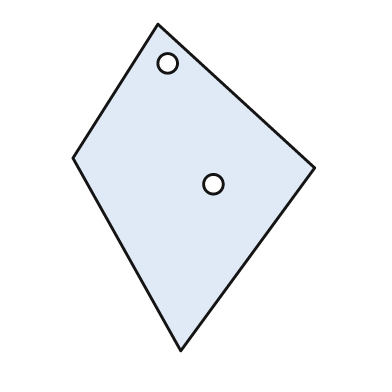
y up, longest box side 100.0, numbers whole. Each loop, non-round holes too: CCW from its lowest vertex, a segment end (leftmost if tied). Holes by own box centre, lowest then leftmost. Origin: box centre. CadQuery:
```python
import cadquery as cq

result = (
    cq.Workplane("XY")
    .moveTo(-4.0, -50.0)
    .lineTo(37.0, 6.0)
    .lineTo(-11.0, 50.0)
    .lineTo(-37.0, 9.0)
    .close()
    .moveTo(6.0, 1.0)
    .circle(3.0)
    .moveTo(-8.0, 38.0)
    .circle(3.0)
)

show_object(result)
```